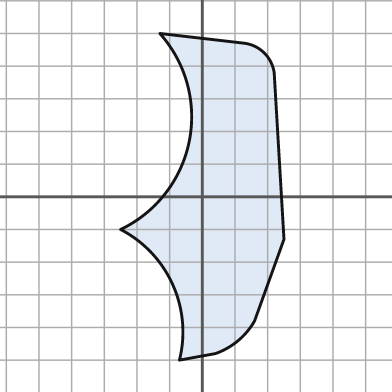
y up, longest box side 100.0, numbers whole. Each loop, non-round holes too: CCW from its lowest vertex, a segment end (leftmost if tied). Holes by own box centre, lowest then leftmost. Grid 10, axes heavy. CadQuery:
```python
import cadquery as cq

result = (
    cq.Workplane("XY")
    .moveTo(-7.0, -50.0)
    .lineTo(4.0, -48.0)
    .threePointArc((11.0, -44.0), (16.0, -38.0))
    .lineTo(25.0, -13.0)
    .lineTo(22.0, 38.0)
    .threePointArc((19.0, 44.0), (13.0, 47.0))
    .lineTo(-13.0, 50.0)
    .threePointArc((-4.0, 17.0), (-25.0, -10.0))
    .threePointArc((-9.0, -27.0), (-7.0, -50.0))
    .close()
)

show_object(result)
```